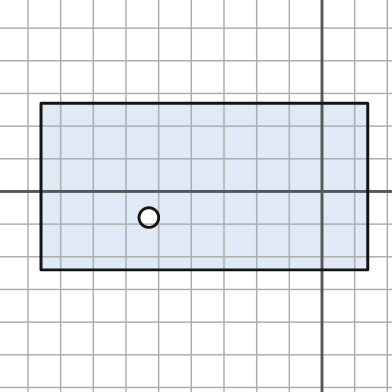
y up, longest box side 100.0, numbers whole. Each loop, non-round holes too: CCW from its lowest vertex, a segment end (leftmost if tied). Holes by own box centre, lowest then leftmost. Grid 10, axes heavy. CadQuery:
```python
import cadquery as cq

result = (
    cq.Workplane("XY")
    .moveTo(-86.0, -24.0)
    .lineTo(14.0, -24.0)
    .lineTo(14.0, 27.0)
    .lineTo(-86.0, 27.0)
    .close()
    .moveTo(-53.0, -8.0)
    .circle(3.0)
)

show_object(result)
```